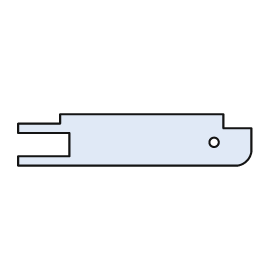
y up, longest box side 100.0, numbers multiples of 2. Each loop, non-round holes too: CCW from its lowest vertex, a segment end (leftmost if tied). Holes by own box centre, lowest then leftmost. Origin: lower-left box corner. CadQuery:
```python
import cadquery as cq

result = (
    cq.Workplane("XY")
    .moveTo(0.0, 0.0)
    .lineTo(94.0, 0.0)
    .threePointArc((98.0, 2.0), (100.0, 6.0))
    .lineTo(100.0, 16.0)
    .lineTo(88.0, 16.0)
    .lineTo(88.0, 22.0)
    .lineTo(18.0, 22.0)
    .lineTo(18.0, 18.0)
    .lineTo(0.0, 18.0)
    .lineTo(0.0, 14.0)
    .lineTo(22.0, 14.0)
    .lineTo(22.0, 4.0)
    .lineTo(0.0, 4.0)
    .close()
    .moveTo(84.0, 10.0)
    .circle(2.0)
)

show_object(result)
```